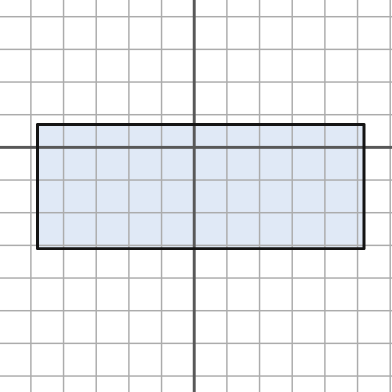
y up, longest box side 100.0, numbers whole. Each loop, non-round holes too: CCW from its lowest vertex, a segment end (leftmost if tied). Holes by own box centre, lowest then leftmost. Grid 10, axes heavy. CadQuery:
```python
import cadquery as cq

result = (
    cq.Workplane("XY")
    .moveTo(-48.0, -31.0)
    .lineTo(52.0, -31.0)
    .lineTo(52.0, 7.0)
    .lineTo(-48.0, 7.0)
    .close()
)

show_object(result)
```